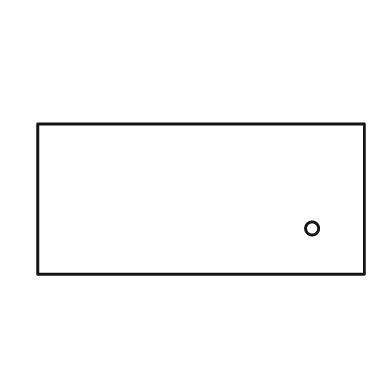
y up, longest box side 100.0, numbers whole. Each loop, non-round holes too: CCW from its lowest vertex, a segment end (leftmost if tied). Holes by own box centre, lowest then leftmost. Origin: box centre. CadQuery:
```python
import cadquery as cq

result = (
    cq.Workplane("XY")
    .moveTo(-50.0, -23.0)
    .lineTo(50.0, -23.0)
    .lineTo(50.0, 23.0)
    .lineTo(-50.0, 23.0)
    .close()
    .moveTo(34.0, -9.0)
    .circle(2.0)
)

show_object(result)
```